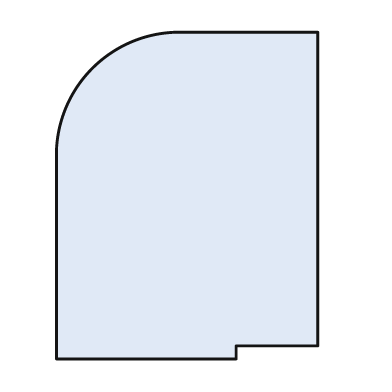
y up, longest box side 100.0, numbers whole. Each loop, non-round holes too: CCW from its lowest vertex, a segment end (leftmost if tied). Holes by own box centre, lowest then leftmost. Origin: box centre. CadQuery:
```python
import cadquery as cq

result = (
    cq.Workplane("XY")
    .moveTo(-40.0, -50.0)
    .lineTo(15.0, -50.0)
    .lineTo(15.0, -46.0)
    .lineTo(40.0, -46.0)
    .lineTo(40.0, 50.0)
    .lineTo(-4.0, 50.0)
    .threePointArc((-29.0, 39.0), (-40.0, 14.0))
    .close()
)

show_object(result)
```